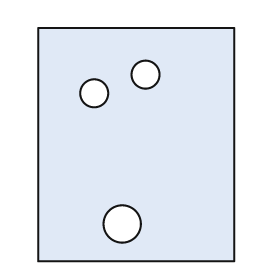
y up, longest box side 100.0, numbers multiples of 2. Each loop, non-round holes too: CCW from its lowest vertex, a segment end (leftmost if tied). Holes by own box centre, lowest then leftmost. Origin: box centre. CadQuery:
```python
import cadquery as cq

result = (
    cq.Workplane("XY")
    .moveTo(-42.0, -50.0)
    .lineTo(42.0, -50.0)
    .lineTo(42.0, 50.0)
    .lineTo(-42.0, 50.0)
    .close()
    .moveTo(-6.0, -34.0)
    .circle(8.0)
    .moveTo(-18.0, 22.0)
    .circle(6.0)
    .moveTo(4.0, 30.0)
    .circle(6.0)
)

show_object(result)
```